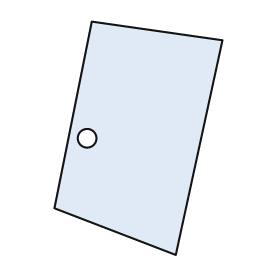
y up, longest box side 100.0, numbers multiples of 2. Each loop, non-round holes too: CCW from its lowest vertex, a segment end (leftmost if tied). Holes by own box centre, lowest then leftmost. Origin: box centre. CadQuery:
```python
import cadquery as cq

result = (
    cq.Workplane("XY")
    .moveTo(16.0, -50.0)
    .lineTo(36.0, 42.0)
    .lineTo(-20.0, 50.0)
    .lineTo(-36.0, -30.0)
    .close()
    .moveTo(-22.0, 0.0)
    .circle(4.0)
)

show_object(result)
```